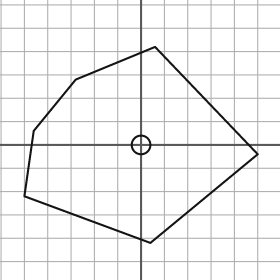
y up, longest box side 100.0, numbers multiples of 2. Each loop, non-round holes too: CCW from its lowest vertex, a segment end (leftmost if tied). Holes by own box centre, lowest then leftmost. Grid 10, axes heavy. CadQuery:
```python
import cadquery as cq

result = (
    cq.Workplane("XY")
    .moveTo(4.0, -42.0)
    .lineTo(50.0, -4.0)
    .lineTo(6.0, 42.0)
    .lineTo(-28.0, 28.0)
    .lineTo(-46.0, 6.0)
    .lineTo(-50.0, -22.0)
    .close()
    .moveTo(0.0, 0.0)
    .circle(4.0)
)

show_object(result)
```